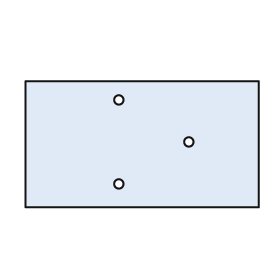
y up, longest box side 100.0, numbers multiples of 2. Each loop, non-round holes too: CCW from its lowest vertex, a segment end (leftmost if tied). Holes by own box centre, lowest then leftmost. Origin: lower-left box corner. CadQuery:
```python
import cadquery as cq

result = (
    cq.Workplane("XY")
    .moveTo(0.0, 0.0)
    .lineTo(100.0, 0.0)
    .lineTo(100.0, 54.0)
    .lineTo(0.0, 54.0)
    .close()
    .moveTo(40.0, 10.0)
    .circle(2.0)
    .moveTo(70.0, 28.0)
    .circle(2.0)
    .moveTo(40.0, 46.0)
    .circle(2.0)
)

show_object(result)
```